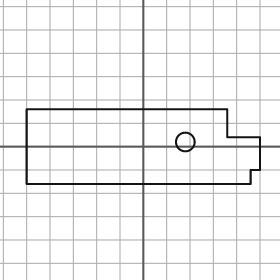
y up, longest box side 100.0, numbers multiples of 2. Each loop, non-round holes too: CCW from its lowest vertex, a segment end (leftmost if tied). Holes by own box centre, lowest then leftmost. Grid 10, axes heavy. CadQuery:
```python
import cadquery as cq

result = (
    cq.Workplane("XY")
    .moveTo(-50.0, -16.0)
    .lineTo(46.0, -16.0)
    .lineTo(46.0, -10.0)
    .lineTo(50.0, -10.0)
    .lineTo(50.0, 4.0)
    .lineTo(36.0, 4.0)
    .lineTo(36.0, 16.0)
    .lineTo(-50.0, 16.0)
    .close()
    .moveTo(18.0, 2.0)
    .circle(4.0)
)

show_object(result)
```